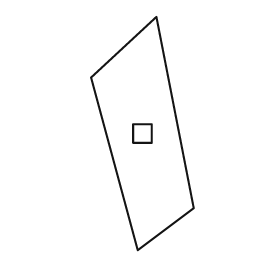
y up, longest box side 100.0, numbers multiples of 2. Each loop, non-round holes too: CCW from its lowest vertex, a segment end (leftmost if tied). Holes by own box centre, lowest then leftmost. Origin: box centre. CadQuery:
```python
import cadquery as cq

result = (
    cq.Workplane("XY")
    .moveTo(-2.0, -50.0)
    .lineTo(22.0, -32.0)
    .lineTo(6.0, 50.0)
    .lineTo(-22.0, 24.0)
    .close()
    .moveTo(-4.0, -4.0)
    .lineTo(4.0, -4.0)
    .lineTo(4.0, 4.0)
    .lineTo(-4.0, 4.0)
    .close()
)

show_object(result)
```